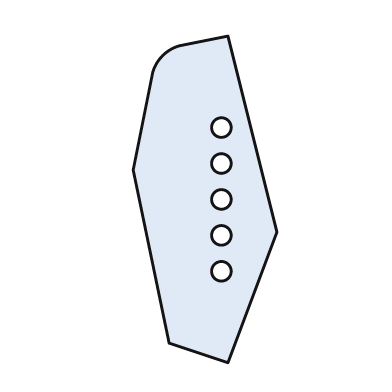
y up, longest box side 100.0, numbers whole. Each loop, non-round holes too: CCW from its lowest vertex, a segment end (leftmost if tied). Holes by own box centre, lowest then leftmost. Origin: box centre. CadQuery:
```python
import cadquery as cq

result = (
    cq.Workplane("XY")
    .moveTo(7.0, -50.0)
    .lineTo(22.0, -10.0)
    .lineTo(7.0, 50.0)
    .lineTo(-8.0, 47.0)
    .threePointArc((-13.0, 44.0), (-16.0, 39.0))
    .lineTo(-22.0, 9.0)
    .lineTo(-11.0, -44.0)
    .close()
    .moveTo(5.0, -22.0)
    .circle(3.0)
    .moveTo(5.0, -11.0)
    .circle(3.0)
    .moveTo(5.0, 0.0)
    .circle(3.0)
    .moveTo(5.0, 11.0)
    .circle(3.0)
    .moveTo(5.0, 22.0)
    .circle(3.0)
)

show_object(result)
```